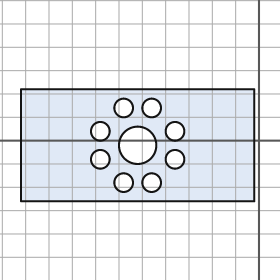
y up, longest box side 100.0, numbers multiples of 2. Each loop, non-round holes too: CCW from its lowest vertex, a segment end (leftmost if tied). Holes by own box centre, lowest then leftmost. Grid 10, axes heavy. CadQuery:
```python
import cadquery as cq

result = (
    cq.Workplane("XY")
    .moveTo(-102.0, -26.0)
    .lineTo(-2.0, -26.0)
    .lineTo(-2.0, 22.0)
    .lineTo(-102.0, 22.0)
    .close()
    .moveTo(-58.0, -18.0)
    .circle(4.0)
    .moveTo(-46.0, -18.0)
    .circle(4.0)
    .moveTo(-68.0, -8.0)
    .circle(4.0)
    .moveTo(-36.0, -8.0)
    .circle(4.0)
    .moveTo(-52.0, -2.0)
    .circle(8.0)
    .moveTo(-68.0, 4.0)
    .circle(4.0)
    .moveTo(-36.0, 4.0)
    .circle(4.0)
    .moveTo(-58.0, 14.0)
    .circle(4.0)
    .moveTo(-46.0, 14.0)
    .circle(4.0)
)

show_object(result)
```